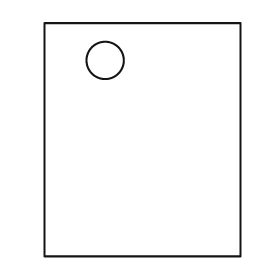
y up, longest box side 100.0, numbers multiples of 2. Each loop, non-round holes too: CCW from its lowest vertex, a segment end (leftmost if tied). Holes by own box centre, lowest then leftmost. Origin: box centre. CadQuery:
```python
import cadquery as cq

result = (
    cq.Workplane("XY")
    .moveTo(-42.0, -50.0)
    .lineTo(42.0, -50.0)
    .lineTo(42.0, 50.0)
    .lineTo(-42.0, 50.0)
    .close()
    .moveTo(-16.0, 34.0)
    .circle(8.0)
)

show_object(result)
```